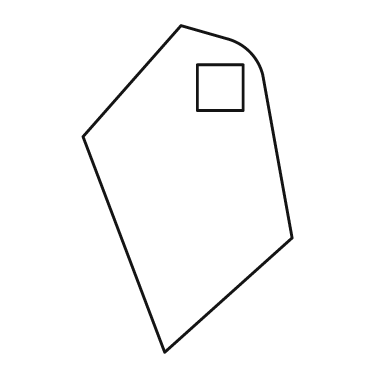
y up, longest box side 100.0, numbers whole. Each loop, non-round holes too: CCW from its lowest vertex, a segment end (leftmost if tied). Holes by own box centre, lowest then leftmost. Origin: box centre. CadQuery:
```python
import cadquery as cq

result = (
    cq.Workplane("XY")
    .moveTo(-7.0, -50.0)
    .lineTo(32.0, -15.0)
    .lineTo(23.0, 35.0)
    .threePointArc((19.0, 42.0), (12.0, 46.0))
    .lineTo(-2.0, 50.0)
    .lineTo(-32.0, 16.0)
    .close()
    .moveTo(3.0, 24.0)
    .lineTo(17.0, 24.0)
    .lineTo(17.0, 38.0)
    .lineTo(3.0, 38.0)
    .close()
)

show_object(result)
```